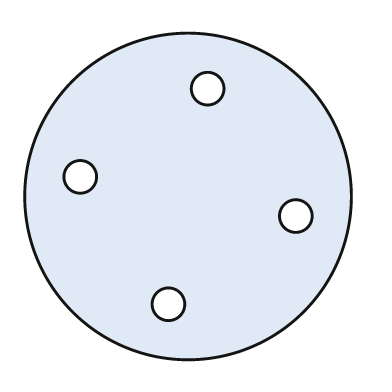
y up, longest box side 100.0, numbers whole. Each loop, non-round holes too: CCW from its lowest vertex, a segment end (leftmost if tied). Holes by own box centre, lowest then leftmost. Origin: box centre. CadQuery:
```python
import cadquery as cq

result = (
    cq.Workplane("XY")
    .moveTo(0.0, 0.0)
    .circle(50.0)
    .moveTo(-6.0, -33.0)
    .circle(5.0)
    .moveTo(33.0, -6.0)
    .circle(5.0)
    .moveTo(-33.0, 6.0)
    .circle(5.0)
    .moveTo(6.0, 33.0)
    .circle(5.0)
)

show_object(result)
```